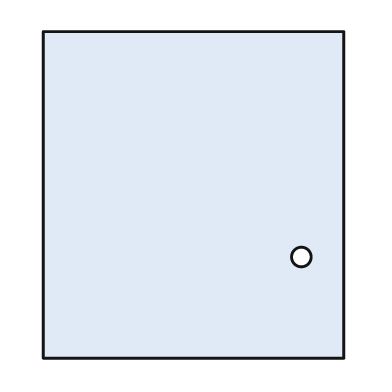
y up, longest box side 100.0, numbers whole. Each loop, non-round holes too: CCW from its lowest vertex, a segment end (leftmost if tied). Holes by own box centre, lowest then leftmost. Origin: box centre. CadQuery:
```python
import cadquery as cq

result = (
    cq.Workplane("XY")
    .moveTo(-46.0, -50.0)
    .lineTo(46.0, -50.0)
    .lineTo(46.0, 50.0)
    .lineTo(-46.0, 50.0)
    .close()
    .moveTo(33.0, -19.0)
    .circle(3.0)
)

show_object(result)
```